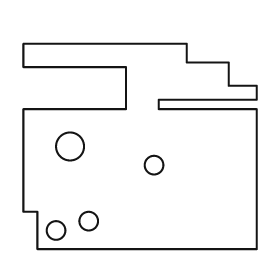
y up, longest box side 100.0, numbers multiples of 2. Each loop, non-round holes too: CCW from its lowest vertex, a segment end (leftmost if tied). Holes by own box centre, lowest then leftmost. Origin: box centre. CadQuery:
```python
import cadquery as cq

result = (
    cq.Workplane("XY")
    .moveTo(-44.0, -44.0)
    .lineTo(50.0, -44.0)
    .lineTo(50.0, 16.0)
    .lineTo(8.0, 16.0)
    .lineTo(8.0, 20.0)
    .lineTo(50.0, 20.0)
    .lineTo(50.0, 26.0)
    .lineTo(38.0, 26.0)
    .lineTo(38.0, 36.0)
    .lineTo(20.0, 36.0)
    .lineTo(20.0, 44.0)
    .lineTo(-50.0, 44.0)
    .lineTo(-50.0, 34.0)
    .lineTo(-6.0, 34.0)
    .lineTo(-6.0, 16.0)
    .lineTo(-50.0, 16.0)
    .lineTo(-50.0, -28.0)
    .lineTo(-44.0, -28.0)
    .close()
    .moveTo(-36.0, -36.0)
    .circle(4.0)
    .moveTo(-22.0, -32.0)
    .circle(4.0)
    .moveTo(6.0, -8.0)
    .circle(4.0)
    .moveTo(-30.0, 0.0)
    .circle(6.0)
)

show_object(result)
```